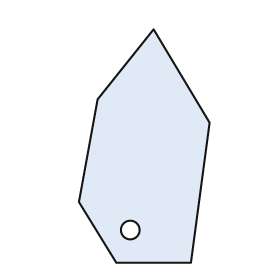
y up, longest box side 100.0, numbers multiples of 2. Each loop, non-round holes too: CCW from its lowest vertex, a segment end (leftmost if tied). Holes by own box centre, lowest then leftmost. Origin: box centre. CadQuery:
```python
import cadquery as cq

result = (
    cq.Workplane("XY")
    .moveTo(-12.0, -50.0)
    .lineTo(20.0, -50.0)
    .lineTo(28.0, 10.0)
    .lineTo(4.0, 50.0)
    .lineTo(-20.0, 20.0)
    .lineTo(-28.0, -24.0)
    .close()
    .moveTo(-6.0, -36.0)
    .circle(4.0)
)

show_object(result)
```